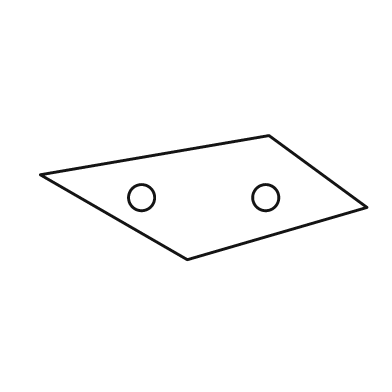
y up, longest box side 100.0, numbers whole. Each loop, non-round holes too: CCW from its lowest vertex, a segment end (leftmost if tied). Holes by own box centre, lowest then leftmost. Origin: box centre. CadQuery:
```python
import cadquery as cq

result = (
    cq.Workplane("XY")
    .moveTo(-5.0, -19.0)
    .lineTo(50.0, -3.0)
    .lineTo(20.0, 19.0)
    .lineTo(-50.0, 7.0)
    .close()
    .moveTo(-19.0, 0.0)
    .circle(4.0)
    .moveTo(19.0, 0.0)
    .circle(4.0)
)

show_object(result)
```